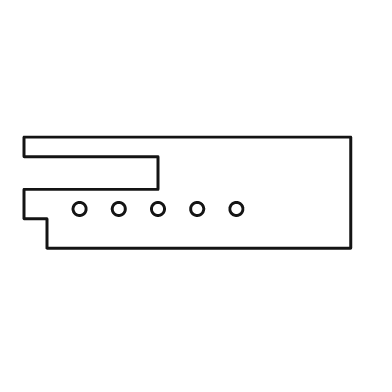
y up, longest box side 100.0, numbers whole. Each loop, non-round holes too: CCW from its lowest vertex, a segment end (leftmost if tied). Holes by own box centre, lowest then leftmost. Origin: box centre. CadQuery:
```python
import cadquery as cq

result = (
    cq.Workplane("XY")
    .moveTo(-43.0, -17.0)
    .lineTo(50.0, -17.0)
    .lineTo(50.0, 17.0)
    .lineTo(-50.0, 17.0)
    .lineTo(-50.0, 11.0)
    .lineTo(-9.0, 11.0)
    .lineTo(-9.0, 1.0)
    .lineTo(-50.0, 1.0)
    .lineTo(-50.0, -8.0)
    .lineTo(-43.0, -8.0)
    .close()
    .moveTo(-33.0, -5.0)
    .circle(2.0)
    .moveTo(-21.0, -5.0)
    .circle(2.0)
    .moveTo(-9.0, -5.0)
    .circle(2.0)
    .moveTo(3.0, -5.0)
    .circle(2.0)
    .moveTo(15.0, -5.0)
    .circle(2.0)
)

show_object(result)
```